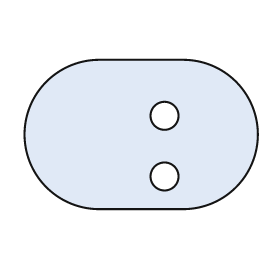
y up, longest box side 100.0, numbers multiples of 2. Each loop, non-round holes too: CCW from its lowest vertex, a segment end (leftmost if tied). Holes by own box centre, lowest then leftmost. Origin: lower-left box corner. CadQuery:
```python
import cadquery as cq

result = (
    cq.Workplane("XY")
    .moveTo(32.0, 0.0)
    .lineTo(68.0, 0.0)
    .threePointArc((100.0, 32.0), (68.0, 64.0))
    .lineTo(32.0, 64.0)
    .threePointArc((0.0, 32.0), (32.0, 0.0))
    .close()
    .moveTo(60.0, 14.0)
    .circle(6.0)
    .moveTo(60.0, 40.0)
    .circle(6.0)
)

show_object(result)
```